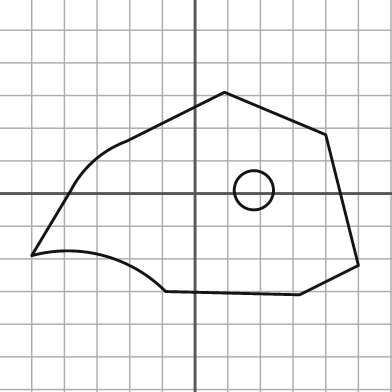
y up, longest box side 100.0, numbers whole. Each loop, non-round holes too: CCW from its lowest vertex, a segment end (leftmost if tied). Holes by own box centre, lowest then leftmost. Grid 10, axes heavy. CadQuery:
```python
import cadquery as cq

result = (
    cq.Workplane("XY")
    .moveTo(32.0, -31.0)
    .lineTo(50.0, -22.0)
    .lineTo(40.0, 18.0)
    .lineTo(9.0, 31.0)
    .lineTo(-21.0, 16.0)
    .threePointArc((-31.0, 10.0), (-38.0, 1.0))
    .lineTo(-50.0, -19.0)
    .threePointArc((-28.0, -19.0), (-9.0, -30.0))
    .close()
    .moveTo(18.0, 1.0)
    .circle(6.0)
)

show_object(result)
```